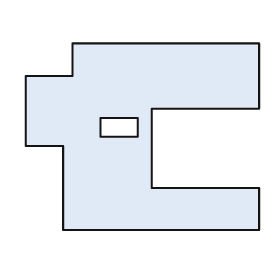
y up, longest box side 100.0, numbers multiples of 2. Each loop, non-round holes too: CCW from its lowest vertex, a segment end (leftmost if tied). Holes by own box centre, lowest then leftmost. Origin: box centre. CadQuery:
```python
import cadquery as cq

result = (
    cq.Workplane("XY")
    .moveTo(-34.0, -40.0)
    .lineTo(50.0, -40.0)
    .lineTo(50.0, -22.0)
    .lineTo(4.0, -22.0)
    .lineTo(4.0, 12.0)
    .lineTo(50.0, 12.0)
    .lineTo(50.0, 40.0)
    .lineTo(-30.0, 40.0)
    .lineTo(-30.0, 26.0)
    .lineTo(-50.0, 26.0)
    .lineTo(-50.0, -4.0)
    .lineTo(-34.0, -4.0)
    .close()
    .moveTo(-18.0, 0.0)
    .lineTo(-2.0, 0.0)
    .lineTo(-2.0, 8.0)
    .lineTo(-18.0, 8.0)
    .close()
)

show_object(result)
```